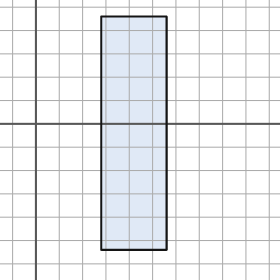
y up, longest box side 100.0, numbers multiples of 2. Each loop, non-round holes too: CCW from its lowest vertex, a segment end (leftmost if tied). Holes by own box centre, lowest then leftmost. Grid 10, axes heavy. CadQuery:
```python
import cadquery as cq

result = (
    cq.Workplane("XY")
    .moveTo(28.0, -54.0)
    .lineTo(56.0, -54.0)
    .lineTo(56.0, 46.0)
    .lineTo(28.0, 46.0)
    .close()
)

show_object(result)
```